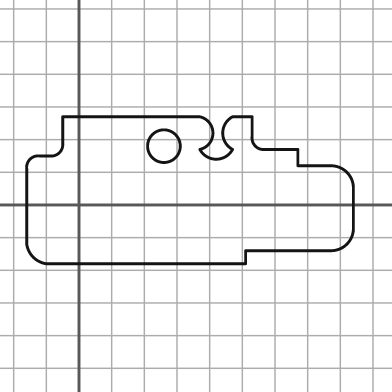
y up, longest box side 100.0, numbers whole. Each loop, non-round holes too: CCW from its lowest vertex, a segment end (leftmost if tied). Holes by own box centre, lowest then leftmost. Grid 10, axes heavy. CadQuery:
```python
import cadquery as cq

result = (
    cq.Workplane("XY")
    .moveTo(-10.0, -18.0)
    .lineTo(51.0, -18.0)
    .lineTo(51.0, -14.0)
    .lineTo(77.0, -14.0)
    .threePointArc((82.0, -12.0), (84.0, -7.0))
    .lineTo(84.0, 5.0)
    .threePointArc((82.0, 10.0), (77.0, 12.0))
    .lineTo(67.0, 12.0)
    .lineTo(67.0, 17.0)
    .lineTo(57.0, 17.0)
    .threePointArc((54.0, 18.0), (53.0, 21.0))
    .lineTo(53.0, 27.0)
    .lineTo(47.0, 27.0)
    .threePointArc((44.0, 22.0), (47.0, 17.0))
    .threePointArc((42.0, 14.0), (37.0, 17.0))
    .threePointArc((41.0, 22.0), (37.0, 27.0))
    .lineTo(-5.0, 27.0)
    .lineTo(-5.0, 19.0)
    .threePointArc((-6.0, 16.0), (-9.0, 15.0))
    .lineTo(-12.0, 15.0)
    .threePointArc((-15.0, 14.0), (-16.0, 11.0))
    .lineTo(-16.0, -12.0)
    .threePointArc((-14.0, -16.0), (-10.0, -18.0))
    .close()
    .moveTo(26.0, 18.0)
    .circle(5.0)
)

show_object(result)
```